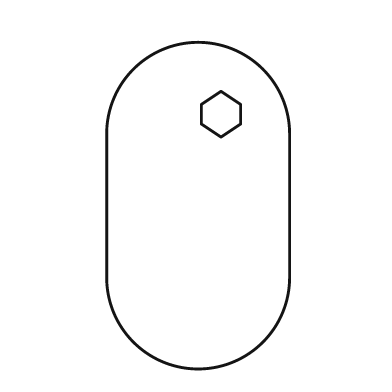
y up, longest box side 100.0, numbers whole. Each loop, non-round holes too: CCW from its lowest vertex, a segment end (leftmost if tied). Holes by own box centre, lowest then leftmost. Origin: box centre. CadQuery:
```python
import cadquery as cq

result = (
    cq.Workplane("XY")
    .moveTo(-28.0, -22.0)
    .threePointArc((0.0, -50.0), (28.0, -22.0))
    .lineTo(28.0, 22.0)
    .threePointArc((0.0, 50.0), (-28.0, 22.0))
    .close()
    .moveTo(7.0, 21.0)
    .lineTo(13.0, 25.0)
    .lineTo(13.0, 31.0)
    .lineTo(7.0, 35.0)
    .lineTo(1.0, 31.0)
    .lineTo(1.0, 25.0)
    .close()
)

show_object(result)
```